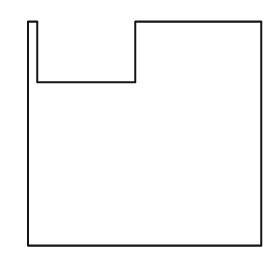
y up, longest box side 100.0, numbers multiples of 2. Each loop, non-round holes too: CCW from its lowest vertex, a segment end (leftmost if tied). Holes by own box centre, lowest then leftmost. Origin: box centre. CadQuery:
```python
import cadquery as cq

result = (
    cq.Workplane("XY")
    .moveTo(-50.0, -48.0)
    .lineTo(50.0, -48.0)
    .lineTo(50.0, 48.0)
    .lineTo(-4.0, 48.0)
    .lineTo(-4.0, 22.0)
    .lineTo(-46.0, 22.0)
    .lineTo(-46.0, 48.0)
    .lineTo(-50.0, 48.0)
    .close()
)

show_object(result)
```